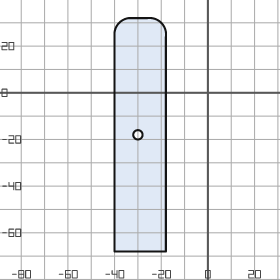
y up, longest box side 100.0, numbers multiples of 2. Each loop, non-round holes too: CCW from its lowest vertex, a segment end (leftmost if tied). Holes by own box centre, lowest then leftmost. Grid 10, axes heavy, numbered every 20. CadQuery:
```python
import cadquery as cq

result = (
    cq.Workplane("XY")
    .moveTo(-40.0, -68.0)
    .lineTo(-18.0, -68.0)
    .lineTo(-18.0, 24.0)
    .threePointArc((-20.0, 30.0), (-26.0, 32.0))
    .lineTo(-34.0, 32.0)
    .threePointArc((-38.0, 30.0), (-40.0, 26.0))
    .close()
    .moveTo(-30.0, -18.0)
    .circle(2.0)
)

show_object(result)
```